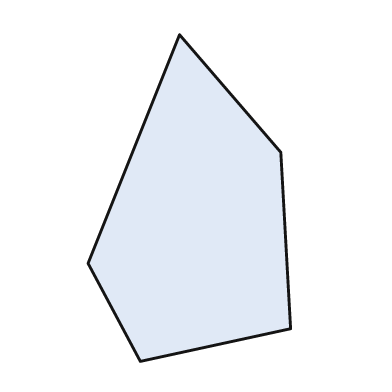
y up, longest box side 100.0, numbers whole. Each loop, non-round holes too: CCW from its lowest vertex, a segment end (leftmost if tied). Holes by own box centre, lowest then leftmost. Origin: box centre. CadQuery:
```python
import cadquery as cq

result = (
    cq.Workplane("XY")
    .moveTo(-15.0, -50.0)
    .lineTo(31.0, -40.0)
    .lineTo(28.0, 14.0)
    .lineTo(-3.0, 50.0)
    .lineTo(-31.0, -20.0)
    .close()
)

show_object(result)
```